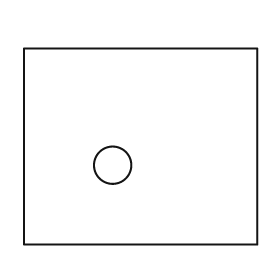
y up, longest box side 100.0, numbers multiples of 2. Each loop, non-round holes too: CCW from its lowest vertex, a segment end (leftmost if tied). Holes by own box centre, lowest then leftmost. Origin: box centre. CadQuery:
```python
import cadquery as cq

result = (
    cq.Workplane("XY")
    .moveTo(-50.0, -42.0)
    .lineTo(50.0, -42.0)
    .lineTo(50.0, 42.0)
    .lineTo(-50.0, 42.0)
    .close()
    .moveTo(-12.0, -8.0)
    .circle(8.0)
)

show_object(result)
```